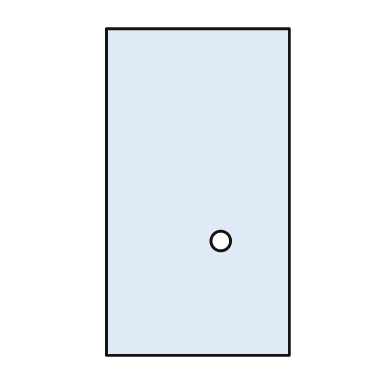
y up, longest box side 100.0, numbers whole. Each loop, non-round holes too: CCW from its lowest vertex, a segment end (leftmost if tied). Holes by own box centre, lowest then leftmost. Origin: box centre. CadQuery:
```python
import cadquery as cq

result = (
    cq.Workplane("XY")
    .moveTo(-28.0, -50.0)
    .lineTo(28.0, -50.0)
    .lineTo(28.0, 50.0)
    .lineTo(-28.0, 50.0)
    .close()
    .moveTo(7.0, -15.0)
    .circle(3.0)
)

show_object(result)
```